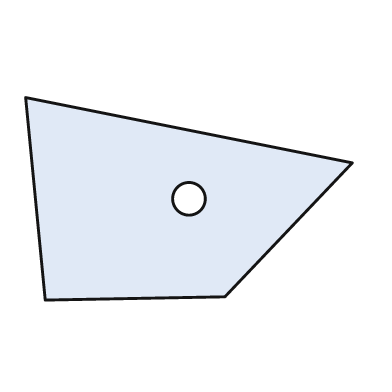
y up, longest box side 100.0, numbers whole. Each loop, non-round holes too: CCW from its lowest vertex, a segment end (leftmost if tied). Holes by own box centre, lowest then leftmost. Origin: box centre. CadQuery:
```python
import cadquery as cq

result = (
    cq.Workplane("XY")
    .moveTo(-44.0, -31.0)
    .lineTo(11.0, -30.0)
    .lineTo(50.0, 11.0)
    .lineTo(-50.0, 31.0)
    .close()
    .moveTo(0.0, 0.0)
    .circle(5.0)
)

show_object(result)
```